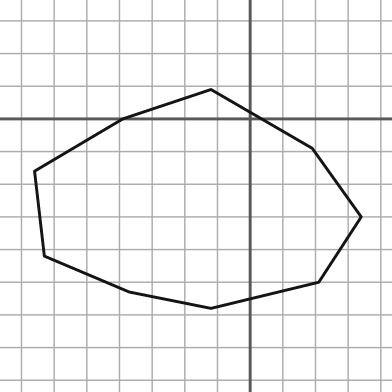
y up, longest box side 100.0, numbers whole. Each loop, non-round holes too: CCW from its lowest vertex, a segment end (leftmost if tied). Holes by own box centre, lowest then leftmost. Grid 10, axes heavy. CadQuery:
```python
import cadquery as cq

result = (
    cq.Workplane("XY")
    .moveTo(-12.0, -58.0)
    .lineTo(21.0, -50.0)
    .lineTo(34.0, -30.0)
    .lineTo(19.0, -9.0)
    .lineTo(-12.0, 9.0)
    .lineTo(-39.0, 0.0)
    .lineTo(-66.0, -16.0)
    .lineTo(-63.0, -42.0)
    .lineTo(-37.0, -53.0)
    .close()
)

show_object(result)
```